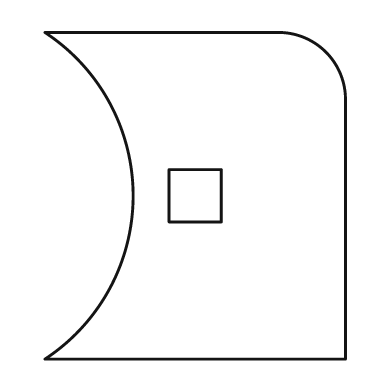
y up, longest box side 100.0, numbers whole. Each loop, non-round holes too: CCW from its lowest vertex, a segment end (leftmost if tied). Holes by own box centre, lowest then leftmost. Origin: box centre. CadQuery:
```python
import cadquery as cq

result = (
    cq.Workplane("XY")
    .moveTo(-46.0, -50.0)
    .lineTo(46.0, -50.0)
    .lineTo(46.0, 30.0)
    .threePointArc((40.0, 44.0), (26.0, 50.0))
    .lineTo(-46.0, 50.0)
    .threePointArc((-19.0, 0.0), (-46.0, -50.0))
    .close()
    .moveTo(-8.0, -8.0)
    .lineTo(8.0, -8.0)
    .lineTo(8.0, 8.0)
    .lineTo(-8.0, 8.0)
    .close()
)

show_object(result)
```